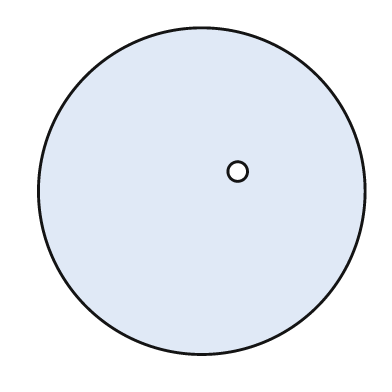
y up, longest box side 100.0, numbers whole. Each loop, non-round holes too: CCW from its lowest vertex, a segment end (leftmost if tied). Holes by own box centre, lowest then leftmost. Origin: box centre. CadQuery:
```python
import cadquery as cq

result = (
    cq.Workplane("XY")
    .moveTo(0.0, 0.0)
    .circle(50.0)
    .moveTo(11.0, 6.0)
    .circle(3.0)
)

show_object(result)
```